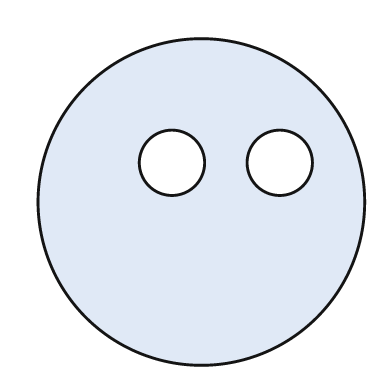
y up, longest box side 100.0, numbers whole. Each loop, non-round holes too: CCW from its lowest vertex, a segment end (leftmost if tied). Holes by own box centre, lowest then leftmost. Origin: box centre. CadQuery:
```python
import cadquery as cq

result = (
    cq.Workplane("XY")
    .moveTo(0.0, 0.0)
    .circle(50.0)
    .moveTo(-9.0, 12.0)
    .circle(10.0)
    .moveTo(24.0, 12.0)
    .circle(10.0)
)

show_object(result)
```